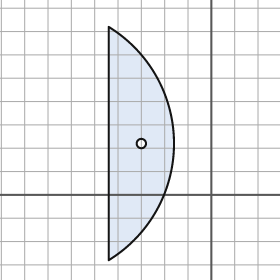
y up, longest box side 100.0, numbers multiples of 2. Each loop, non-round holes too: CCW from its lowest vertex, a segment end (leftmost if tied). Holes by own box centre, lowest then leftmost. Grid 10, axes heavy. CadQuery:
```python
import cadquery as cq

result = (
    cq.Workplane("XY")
    .moveTo(-44.0, -28.0)
    .threePointArc((-16.0, 22.0), (-44.0, 72.0))
    .close()
    .moveTo(-30.0, 22.0)
    .circle(2.0)
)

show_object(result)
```